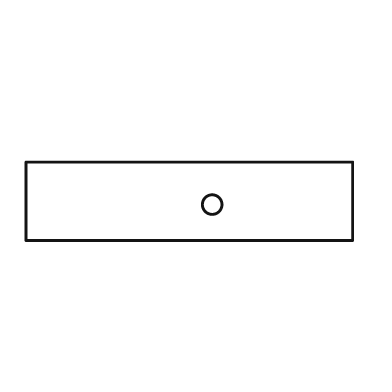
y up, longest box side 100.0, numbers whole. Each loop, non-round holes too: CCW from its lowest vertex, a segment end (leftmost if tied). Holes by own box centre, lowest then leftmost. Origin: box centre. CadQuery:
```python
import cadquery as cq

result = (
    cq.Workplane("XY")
    .moveTo(-50.0, -12.0)
    .lineTo(50.0, -12.0)
    .lineTo(50.0, 12.0)
    .lineTo(-50.0, 12.0)
    .close()
    .moveTo(7.0, -1.0)
    .circle(3.0)
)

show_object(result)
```